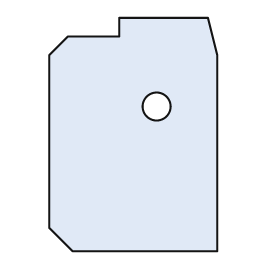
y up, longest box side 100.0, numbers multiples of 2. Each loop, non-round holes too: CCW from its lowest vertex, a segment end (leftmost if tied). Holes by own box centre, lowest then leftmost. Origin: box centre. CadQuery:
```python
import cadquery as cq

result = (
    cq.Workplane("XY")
    .moveTo(-26.0, -50.0)
    .lineTo(36.0, -50.0)
    .lineTo(36.0, 34.0)
    .lineTo(32.0, 50.0)
    .lineTo(-6.0, 50.0)
    .lineTo(-6.0, 42.0)
    .lineTo(-28.0, 42.0)
    .lineTo(-36.0, 34.0)
    .lineTo(-36.0, -40.0)
    .close()
    .moveTo(10.0, 12.0)
    .circle(6.0)
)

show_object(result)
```